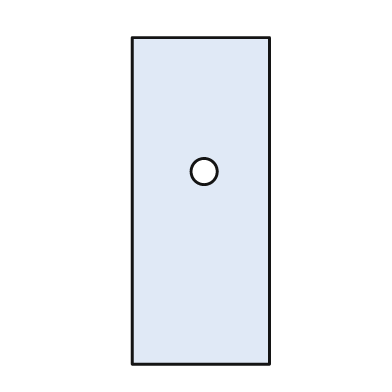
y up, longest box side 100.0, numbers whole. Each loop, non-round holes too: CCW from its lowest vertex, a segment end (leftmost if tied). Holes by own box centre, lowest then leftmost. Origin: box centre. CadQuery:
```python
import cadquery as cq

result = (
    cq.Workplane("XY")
    .moveTo(-21.0, -50.0)
    .lineTo(21.0, -50.0)
    .lineTo(21.0, 50.0)
    .lineTo(-21.0, 50.0)
    .close()
    .moveTo(1.0, 9.0)
    .circle(4.0)
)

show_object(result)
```